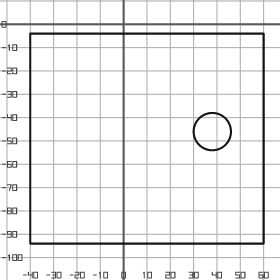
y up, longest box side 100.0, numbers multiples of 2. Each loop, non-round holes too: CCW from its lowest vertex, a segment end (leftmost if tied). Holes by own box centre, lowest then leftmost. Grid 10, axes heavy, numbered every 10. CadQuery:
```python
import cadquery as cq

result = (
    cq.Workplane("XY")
    .moveTo(-40.0, -94.0)
    .lineTo(60.0, -94.0)
    .lineTo(60.0, -4.0)
    .lineTo(-40.0, -4.0)
    .close()
    .moveTo(38.0, -46.0)
    .circle(8.0)
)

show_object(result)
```